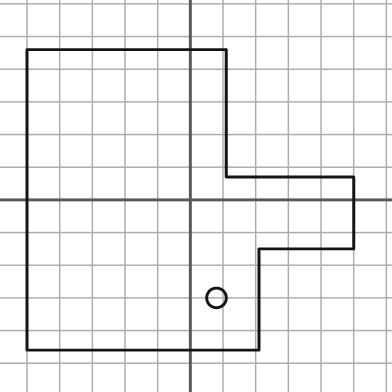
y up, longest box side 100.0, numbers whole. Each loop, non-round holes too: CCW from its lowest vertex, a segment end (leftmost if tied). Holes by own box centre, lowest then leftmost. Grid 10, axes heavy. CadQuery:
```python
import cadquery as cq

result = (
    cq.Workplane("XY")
    .moveTo(-50.0, -46.0)
    .lineTo(21.0, -46.0)
    .lineTo(21.0, -15.0)
    .lineTo(50.0, -15.0)
    .lineTo(50.0, 7.0)
    .lineTo(11.0, 7.0)
    .lineTo(11.0, 46.0)
    .lineTo(-50.0, 46.0)
    .close()
    .moveTo(8.0, -30.0)
    .circle(3.0)
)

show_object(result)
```